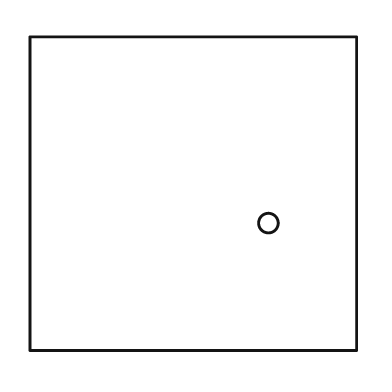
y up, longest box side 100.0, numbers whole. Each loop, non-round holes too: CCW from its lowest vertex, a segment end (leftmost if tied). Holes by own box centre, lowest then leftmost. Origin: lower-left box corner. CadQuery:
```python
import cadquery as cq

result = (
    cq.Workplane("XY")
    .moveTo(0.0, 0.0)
    .lineTo(100.0, 0.0)
    .lineTo(100.0, 96.0)
    .lineTo(0.0, 96.0)
    .close()
    .moveTo(73.0, 39.0)
    .circle(3.0)
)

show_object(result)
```